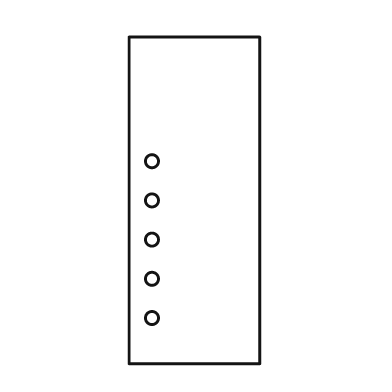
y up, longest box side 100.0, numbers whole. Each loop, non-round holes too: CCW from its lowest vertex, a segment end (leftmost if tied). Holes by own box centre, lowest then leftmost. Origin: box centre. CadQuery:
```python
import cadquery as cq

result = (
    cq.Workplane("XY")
    .moveTo(-20.0, -50.0)
    .lineTo(20.0, -50.0)
    .lineTo(20.0, 50.0)
    .lineTo(-20.0, 50.0)
    .close()
    .moveTo(-13.0, -36.0)
    .circle(2.0)
    .moveTo(-13.0, -24.0)
    .circle(2.0)
    .moveTo(-13.0, -12.0)
    .circle(2.0)
    .moveTo(-13.0, 0.0)
    .circle(2.0)
    .moveTo(-13.0, 12.0)
    .circle(2.0)
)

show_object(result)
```